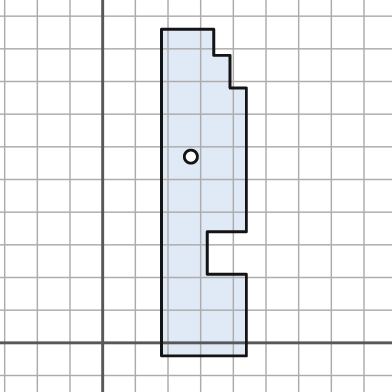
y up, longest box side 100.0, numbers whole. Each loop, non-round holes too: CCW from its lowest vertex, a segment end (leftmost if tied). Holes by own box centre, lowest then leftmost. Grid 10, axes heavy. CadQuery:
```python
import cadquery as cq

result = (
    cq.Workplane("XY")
    .moveTo(18.0, -4.0)
    .lineTo(44.0, -4.0)
    .lineTo(44.0, 21.0)
    .lineTo(32.0, 21.0)
    .lineTo(32.0, 34.0)
    .lineTo(44.0, 34.0)
    .lineTo(44.0, 78.0)
    .lineTo(39.0, 78.0)
    .lineTo(39.0, 88.0)
    .lineTo(34.0, 88.0)
    .lineTo(34.0, 96.0)
    .lineTo(18.0, 96.0)
    .close()
    .moveTo(27.0, 57.0)
    .circle(2.0)
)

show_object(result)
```